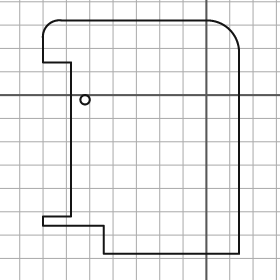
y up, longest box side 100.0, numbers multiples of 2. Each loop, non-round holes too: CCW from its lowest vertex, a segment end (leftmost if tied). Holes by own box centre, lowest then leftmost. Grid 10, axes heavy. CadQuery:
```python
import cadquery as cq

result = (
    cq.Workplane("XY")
    .moveTo(-44.0, -68.0)
    .lineTo(14.0, -68.0)
    .lineTo(14.0, 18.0)
    .threePointArc((10.0, 28.0), (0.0, 32.0))
    .lineTo(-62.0, 32.0)
    .threePointArc((-68.0, 30.0), (-70.0, 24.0))
    .lineTo(-70.0, 14.0)
    .lineTo(-58.0, 14.0)
    .lineTo(-58.0, -52.0)
    .lineTo(-70.0, -52.0)
    .lineTo(-70.0, -56.0)
    .lineTo(-44.0, -56.0)
    .close()
    .moveTo(-52.0, -2.0)
    .circle(2.0)
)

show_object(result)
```